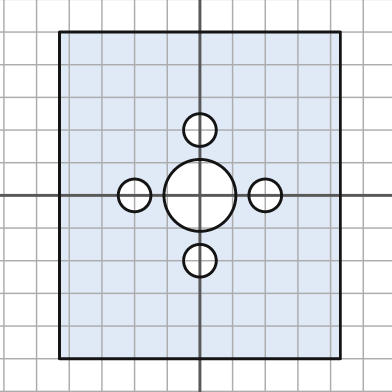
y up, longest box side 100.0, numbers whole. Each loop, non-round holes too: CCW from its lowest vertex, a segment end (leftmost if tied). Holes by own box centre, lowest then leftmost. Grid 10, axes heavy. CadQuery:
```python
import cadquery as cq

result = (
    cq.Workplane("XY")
    .moveTo(-43.0, -50.0)
    .lineTo(43.0, -50.0)
    .lineTo(43.0, 50.0)
    .lineTo(-43.0, 50.0)
    .close()
    .moveTo(0.0, -20.0)
    .circle(5.0)
    .moveTo(-20.0, 0.0)
    .circle(5.0)
    .moveTo(0.0, 0.0)
    .circle(11.0)
    .moveTo(20.0, 0.0)
    .circle(5.0)
    .moveTo(0.0, 20.0)
    .circle(5.0)
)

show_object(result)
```